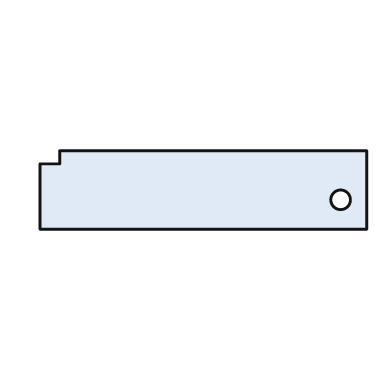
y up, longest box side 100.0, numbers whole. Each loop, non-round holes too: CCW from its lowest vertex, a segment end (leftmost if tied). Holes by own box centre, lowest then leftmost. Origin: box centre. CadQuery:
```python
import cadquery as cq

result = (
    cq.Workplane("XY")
    .moveTo(-50.0, -12.0)
    .lineTo(50.0, -12.0)
    .lineTo(50.0, 12.0)
    .lineTo(-44.0, 12.0)
    .lineTo(-44.0, 8.0)
    .lineTo(-50.0, 8.0)
    .close()
    .moveTo(42.0, -3.0)
    .circle(3.0)
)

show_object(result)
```